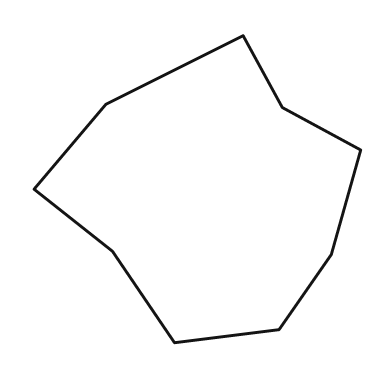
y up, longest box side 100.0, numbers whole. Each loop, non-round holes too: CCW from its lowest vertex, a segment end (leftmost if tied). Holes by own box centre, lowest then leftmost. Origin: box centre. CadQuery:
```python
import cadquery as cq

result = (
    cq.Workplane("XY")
    .moveTo(-7.0, -47.0)
    .lineTo(25.0, -43.0)
    .lineTo(41.0, -20.0)
    .lineTo(50.0, 12.0)
    .lineTo(26.0, 25.0)
    .lineTo(14.0, 47.0)
    .lineTo(-28.0, 26.0)
    .lineTo(-50.0, 0.0)
    .lineTo(-26.0, -19.0)
    .close()
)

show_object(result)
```